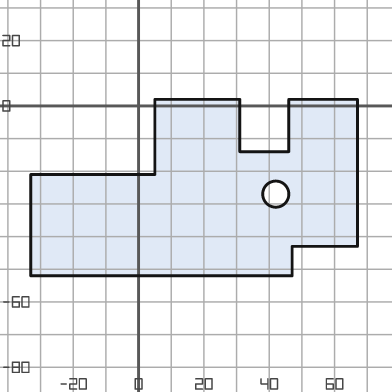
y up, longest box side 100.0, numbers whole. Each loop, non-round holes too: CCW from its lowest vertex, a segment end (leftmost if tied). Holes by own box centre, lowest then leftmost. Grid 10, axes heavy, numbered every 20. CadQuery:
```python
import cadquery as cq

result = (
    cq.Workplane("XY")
    .moveTo(-33.0, -52.0)
    .lineTo(47.0, -52.0)
    .lineTo(47.0, -43.0)
    .lineTo(67.0, -43.0)
    .lineTo(67.0, 2.0)
    .lineTo(46.0, 2.0)
    .lineTo(46.0, -14.0)
    .lineTo(31.0, -14.0)
    .lineTo(31.0, 2.0)
    .lineTo(5.0, 2.0)
    .lineTo(5.0, -21.0)
    .lineTo(-33.0, -21.0)
    .close()
    .moveTo(42.0, -27.0)
    .circle(4.0)
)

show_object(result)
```